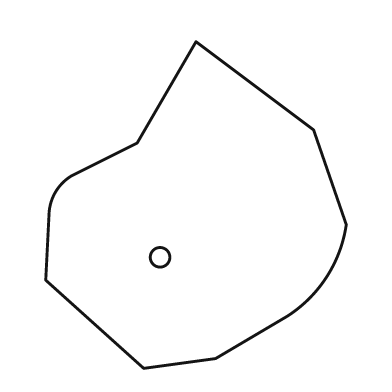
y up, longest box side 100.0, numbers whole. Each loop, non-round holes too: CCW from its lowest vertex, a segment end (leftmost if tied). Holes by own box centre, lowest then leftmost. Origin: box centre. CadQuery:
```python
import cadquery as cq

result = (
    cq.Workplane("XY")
    .moveTo(-16.0, -50.0)
    .lineTo(6.0, -47.0)
    .lineTo(28.0, -34.0)
    .threePointArc((40.0, -22.0), (46.0, -6.0))
    .lineTo(36.0, 23.0)
    .lineTo(0.0, 50.0)
    .lineTo(-18.0, 19.0)
    .lineTo(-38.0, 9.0)
    .threePointArc((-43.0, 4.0), (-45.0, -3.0))
    .lineTo(-46.0, -23.0)
    .close()
    .moveTo(-11.0, -16.0)
    .circle(3.0)
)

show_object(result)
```